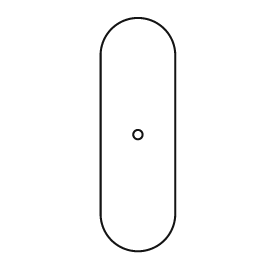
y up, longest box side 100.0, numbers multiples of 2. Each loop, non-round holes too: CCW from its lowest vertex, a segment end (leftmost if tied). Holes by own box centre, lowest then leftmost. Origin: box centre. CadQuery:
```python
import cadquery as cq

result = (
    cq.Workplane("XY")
    .moveTo(-16.0, -34.0)
    .threePointArc((0.0, -50.0), (16.0, -34.0))
    .lineTo(16.0, 34.0)
    .threePointArc((0.0, 50.0), (-16.0, 34.0))
    .close()
    .moveTo(0.0, 0.0)
    .circle(2.0)
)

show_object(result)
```